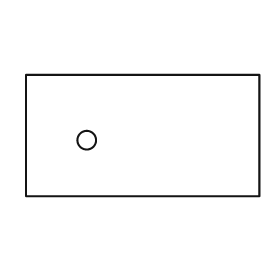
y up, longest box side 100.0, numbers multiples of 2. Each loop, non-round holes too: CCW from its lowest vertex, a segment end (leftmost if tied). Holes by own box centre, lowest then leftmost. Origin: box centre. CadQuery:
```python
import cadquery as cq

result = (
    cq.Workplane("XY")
    .moveTo(-50.0, -26.0)
    .lineTo(50.0, -26.0)
    .lineTo(50.0, 26.0)
    .lineTo(-50.0, 26.0)
    .close()
    .moveTo(-24.0, -2.0)
    .circle(4.0)
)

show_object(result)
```